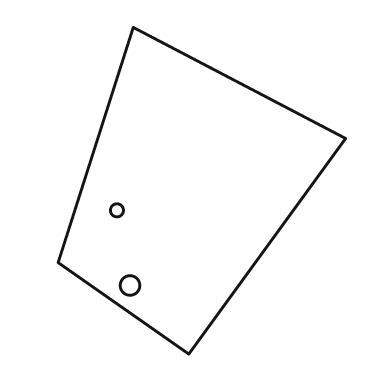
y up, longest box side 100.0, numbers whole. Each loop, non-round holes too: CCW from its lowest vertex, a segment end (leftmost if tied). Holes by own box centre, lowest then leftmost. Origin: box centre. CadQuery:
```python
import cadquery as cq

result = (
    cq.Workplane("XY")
    .moveTo(-4.0, -50.0)
    .lineTo(44.0, 16.0)
    .lineTo(-21.0, 50.0)
    .lineTo(-44.0, -22.0)
    .close()
    .moveTo(-22.0, -29.0)
    .circle(3.0)
    .moveTo(-26.0, -6.0)
    .circle(2.0)
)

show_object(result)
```